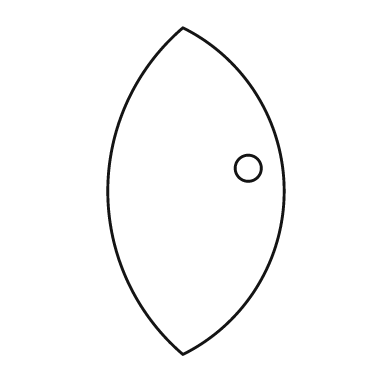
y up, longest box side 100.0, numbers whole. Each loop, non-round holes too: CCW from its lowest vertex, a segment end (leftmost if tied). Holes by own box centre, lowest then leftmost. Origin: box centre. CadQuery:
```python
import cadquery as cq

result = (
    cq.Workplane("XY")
    .moveTo(-4.0, -50.0)
    .threePointArc((27.0, 0.0), (-4.0, 50.0))
    .threePointArc((-27.0, 0.0), (-4.0, -50.0))
    .close()
    .moveTo(16.0, 7.0)
    .circle(4.0)
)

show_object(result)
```